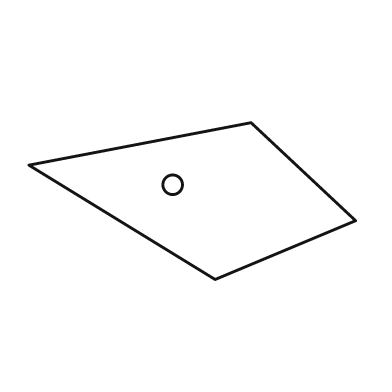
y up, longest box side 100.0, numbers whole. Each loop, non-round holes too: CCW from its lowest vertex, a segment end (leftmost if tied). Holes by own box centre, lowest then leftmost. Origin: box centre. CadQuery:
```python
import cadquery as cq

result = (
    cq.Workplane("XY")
    .moveTo(7.0, -24.0)
    .lineTo(50.0, -6.0)
    .lineTo(18.0, 24.0)
    .lineTo(-50.0, 11.0)
    .close()
    .moveTo(-6.0, 5.0)
    .circle(3.0)
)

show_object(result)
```